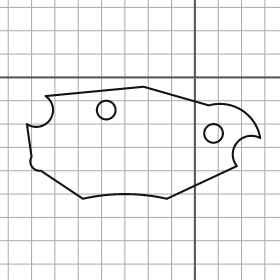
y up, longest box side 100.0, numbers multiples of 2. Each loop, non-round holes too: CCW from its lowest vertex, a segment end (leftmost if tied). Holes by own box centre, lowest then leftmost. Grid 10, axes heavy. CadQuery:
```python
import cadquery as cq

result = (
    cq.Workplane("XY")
    .moveTo(-48.0, -52.0)
    .threePointArc((-30.0, -50.0), (-12.0, -52.0))
    .lineTo(18.0, -38.0)
    .threePointArc((18.0, -28.0), (28.0, -26.0))
    .threePointArc((20.0, -14.0), (6.0, -12.0))
    .lineTo(-22.0, -4.0)
    .lineTo(-64.0, -8.0)
    .threePointArc((-62.0, -18.0), (-72.0, -20.0))
    .lineTo(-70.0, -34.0)
    .threePointArc((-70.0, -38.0), (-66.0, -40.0))
    .close()
    .moveTo(8.0, -24.0)
    .circle(4.0)
    .moveTo(-38.0, -14.0)
    .circle(4.0)
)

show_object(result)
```